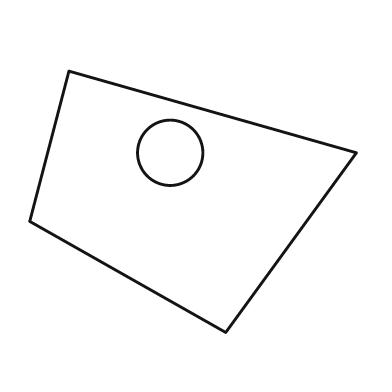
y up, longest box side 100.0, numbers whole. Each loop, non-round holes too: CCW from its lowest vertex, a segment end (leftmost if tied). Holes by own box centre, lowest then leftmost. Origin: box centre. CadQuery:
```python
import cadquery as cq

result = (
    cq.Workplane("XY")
    .moveTo(10.0, -40.0)
    .lineTo(50.0, 15.0)
    .lineTo(-38.0, 40.0)
    .lineTo(-50.0, -6.0)
    .close()
    .moveTo(-7.0, 15.0)
    .circle(10.0)
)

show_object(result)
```